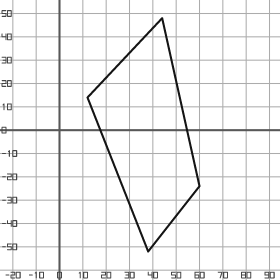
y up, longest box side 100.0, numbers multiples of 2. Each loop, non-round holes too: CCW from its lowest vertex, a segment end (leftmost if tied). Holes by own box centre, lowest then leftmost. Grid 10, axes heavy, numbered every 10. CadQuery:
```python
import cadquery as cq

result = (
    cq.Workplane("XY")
    .moveTo(38.0, -52.0)
    .lineTo(60.0, -24.0)
    .lineTo(44.0, 48.0)
    .lineTo(12.0, 14.0)
    .close()
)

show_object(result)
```